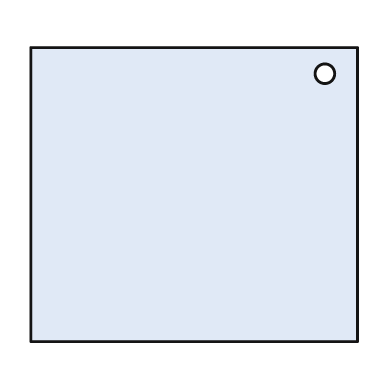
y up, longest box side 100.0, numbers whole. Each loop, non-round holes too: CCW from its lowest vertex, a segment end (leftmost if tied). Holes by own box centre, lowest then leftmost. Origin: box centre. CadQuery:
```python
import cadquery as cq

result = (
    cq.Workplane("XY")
    .moveTo(-50.0, -45.0)
    .lineTo(50.0, -45.0)
    .lineTo(50.0, 45.0)
    .lineTo(-50.0, 45.0)
    .close()
    .moveTo(40.0, 37.0)
    .circle(3.0)
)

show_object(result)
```